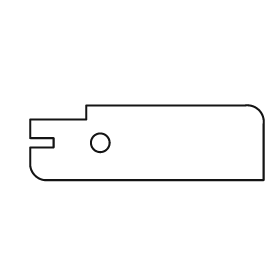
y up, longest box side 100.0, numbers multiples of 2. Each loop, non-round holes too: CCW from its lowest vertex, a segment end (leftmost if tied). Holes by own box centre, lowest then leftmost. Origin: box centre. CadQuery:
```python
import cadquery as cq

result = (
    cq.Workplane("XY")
    .moveTo(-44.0, -16.0)
    .lineTo(50.0, -16.0)
    .lineTo(50.0, 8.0)
    .threePointArc((48.0, 14.0), (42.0, 16.0))
    .lineTo(-26.0, 16.0)
    .lineTo(-26.0, 10.0)
    .lineTo(-50.0, 10.0)
    .lineTo(-50.0, 2.0)
    .lineTo(-40.0, 2.0)
    .lineTo(-40.0, -2.0)
    .lineTo(-50.0, -2.0)
    .lineTo(-50.0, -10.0)
    .threePointArc((-48.0, -14.0), (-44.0, -16.0))
    .close()
    .moveTo(-20.0, 0.0)
    .circle(4.0)
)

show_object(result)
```